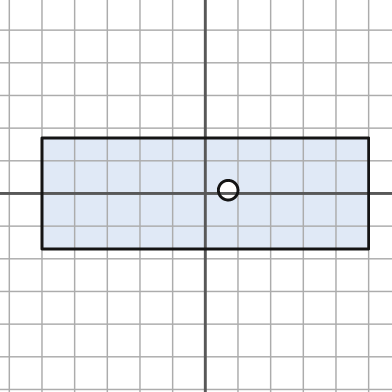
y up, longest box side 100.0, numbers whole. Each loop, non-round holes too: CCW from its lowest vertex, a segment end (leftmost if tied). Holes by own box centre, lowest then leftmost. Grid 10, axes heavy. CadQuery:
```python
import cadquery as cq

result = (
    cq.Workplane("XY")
    .moveTo(-50.0, -17.0)
    .lineTo(50.0, -17.0)
    .lineTo(50.0, 17.0)
    .lineTo(-50.0, 17.0)
    .close()
    .moveTo(7.0, 1.0)
    .circle(3.0)
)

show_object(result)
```